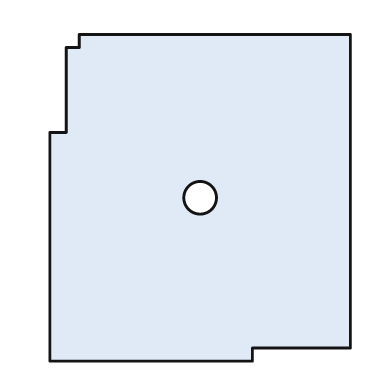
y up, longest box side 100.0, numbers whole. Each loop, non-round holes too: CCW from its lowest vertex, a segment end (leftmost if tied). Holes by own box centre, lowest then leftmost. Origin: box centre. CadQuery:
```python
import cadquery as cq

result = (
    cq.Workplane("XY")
    .moveTo(-46.0, -50.0)
    .lineTo(16.0, -50.0)
    .lineTo(16.0, -46.0)
    .lineTo(46.0, -46.0)
    .lineTo(46.0, 50.0)
    .lineTo(-37.0, 50.0)
    .lineTo(-37.0, 46.0)
    .lineTo(-41.0, 46.0)
    .lineTo(-41.0, 20.0)
    .lineTo(-46.0, 20.0)
    .close()
    .moveTo(0.0, 0.0)
    .circle(5.0)
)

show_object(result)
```